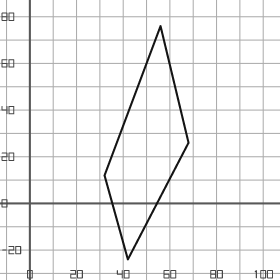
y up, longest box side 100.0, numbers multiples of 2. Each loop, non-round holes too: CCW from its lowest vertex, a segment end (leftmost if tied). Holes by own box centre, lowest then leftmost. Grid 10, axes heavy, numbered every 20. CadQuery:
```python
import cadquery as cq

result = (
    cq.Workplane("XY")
    .moveTo(42.0, -24.0)
    .lineTo(68.0, 26.0)
    .lineTo(56.0, 76.0)
    .lineTo(32.0, 12.0)
    .close()
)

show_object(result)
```